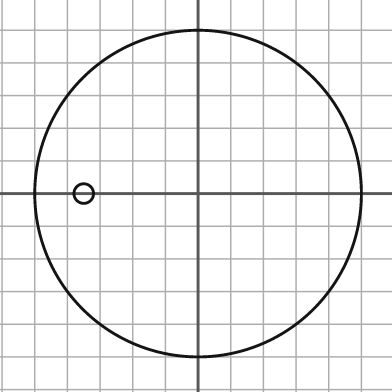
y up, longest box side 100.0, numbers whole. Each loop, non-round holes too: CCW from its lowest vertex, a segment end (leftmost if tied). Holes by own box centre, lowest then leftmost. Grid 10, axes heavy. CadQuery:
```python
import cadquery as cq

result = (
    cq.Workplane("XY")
    .moveTo(0.0, 0.0)
    .circle(50.0)
    .moveTo(-35.0, 0.0)
    .circle(3.0)
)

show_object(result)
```